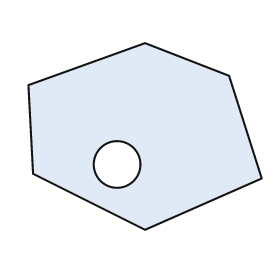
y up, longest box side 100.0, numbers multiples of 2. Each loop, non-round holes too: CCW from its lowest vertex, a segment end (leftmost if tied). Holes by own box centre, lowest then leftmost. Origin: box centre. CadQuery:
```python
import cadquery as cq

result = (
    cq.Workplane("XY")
    .moveTo(0.0, -40.0)
    .lineTo(50.0, -18.0)
    .lineTo(36.0, 26.0)
    .lineTo(0.0, 40.0)
    .lineTo(-50.0, 22.0)
    .lineTo(-48.0, -16.0)
    .close()
    .moveTo(-12.0, -12.0)
    .circle(10.0)
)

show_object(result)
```